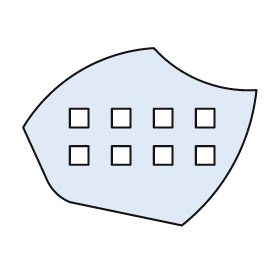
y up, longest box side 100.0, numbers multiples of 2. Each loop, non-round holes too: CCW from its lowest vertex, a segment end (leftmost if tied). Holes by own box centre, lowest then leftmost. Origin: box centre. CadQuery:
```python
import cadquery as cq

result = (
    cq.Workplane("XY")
    .moveTo(18.0, -38.0)
    .threePointArc((40.0, -12.0), (50.0, 20.0))
    .threePointArc((26.0, 24.0), (6.0, 38.0))
    .threePointArc((-26.0, 28.0), (-50.0, 4.0))
    .lineTo(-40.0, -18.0)
    .threePointArc((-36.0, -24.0), (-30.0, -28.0))
    .close()
    .moveTo(-30.0, -12.0)
    .lineTo(-22.0, -12.0)
    .lineTo(-22.0, -4.0)
    .lineTo(-30.0, -4.0)
    .close()
    .moveTo(-12.0, -12.0)
    .lineTo(-4.0, -12.0)
    .lineTo(-4.0, -4.0)
    .lineTo(-12.0, -4.0)
    .close()
    .moveTo(6.0, -12.0)
    .lineTo(14.0, -12.0)
    .lineTo(14.0, -4.0)
    .lineTo(6.0, -4.0)
    .close()
    .moveTo(24.0, -12.0)
    .lineTo(32.0, -12.0)
    .lineTo(32.0, -4.0)
    .lineTo(24.0, -4.0)
    .close()
    .moveTo(-30.0, 4.0)
    .lineTo(-22.0, 4.0)
    .lineTo(-22.0, 12.0)
    .lineTo(-30.0, 12.0)
    .close()
    .moveTo(-12.0, 4.0)
    .lineTo(-4.0, 4.0)
    .lineTo(-4.0, 12.0)
    .lineTo(-12.0, 12.0)
    .close()
    .moveTo(6.0, 4.0)
    .lineTo(14.0, 4.0)
    .lineTo(14.0, 12.0)
    .lineTo(6.0, 12.0)
    .close()
    .moveTo(24.0, 4.0)
    .lineTo(32.0, 4.0)
    .lineTo(32.0, 12.0)
    .lineTo(24.0, 12.0)
    .close()
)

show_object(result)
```